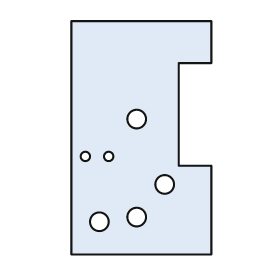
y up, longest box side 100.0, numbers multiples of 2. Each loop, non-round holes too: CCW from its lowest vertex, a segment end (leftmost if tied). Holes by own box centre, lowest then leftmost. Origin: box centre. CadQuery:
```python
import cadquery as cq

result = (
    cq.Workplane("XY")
    .moveTo(-30.0, -50.0)
    .lineTo(30.0, -50.0)
    .lineTo(30.0, -12.0)
    .lineTo(16.0, -12.0)
    .lineTo(16.0, 32.0)
    .lineTo(30.0, 32.0)
    .lineTo(30.0, 50.0)
    .lineTo(-30.0, 50.0)
    .close()
    .moveTo(-18.0, -36.0)
    .circle(4.0)
    .moveTo(-2.0, -34.0)
    .circle(4.0)
    .moveTo(10.0, -20.0)
    .circle(4.0)
    .moveTo(-24.0, -8.0)
    .circle(2.0)
    .moveTo(-14.0, -8.0)
    .circle(2.0)
    .moveTo(-2.0, 8.0)
    .circle(4.0)
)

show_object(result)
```